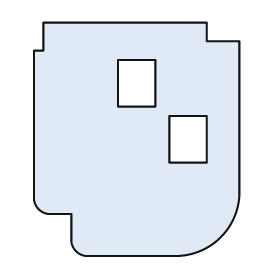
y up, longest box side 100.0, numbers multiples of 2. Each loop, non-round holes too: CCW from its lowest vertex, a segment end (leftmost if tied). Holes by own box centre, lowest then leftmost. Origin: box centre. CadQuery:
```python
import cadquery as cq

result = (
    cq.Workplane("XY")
    .moveTo(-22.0, -50.0)
    .lineTo(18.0, -50.0)
    .threePointArc((36.0, -42.0), (44.0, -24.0))
    .lineTo(44.0, 42.0)
    .lineTo(30.0, 42.0)
    .lineTo(30.0, 50.0)
    .lineTo(-40.0, 50.0)
    .lineTo(-40.0, 38.0)
    .lineTo(-44.0, 38.0)
    .lineTo(-44.0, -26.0)
    .threePointArc((-42.0, -30.0), (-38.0, -32.0))
    .lineTo(-28.0, -32.0)
    .lineTo(-28.0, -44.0)
    .threePointArc((-26.0, -48.0), (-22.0, -50.0))
    .close()
    .moveTo(14.0, -10.0)
    .lineTo(30.0, -10.0)
    .lineTo(30.0, 10.0)
    .lineTo(14.0, 10.0)
    .close()
    .moveTo(-8.0, 14.0)
    .lineTo(8.0, 14.0)
    .lineTo(8.0, 34.0)
    .lineTo(-8.0, 34.0)
    .close()
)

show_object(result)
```